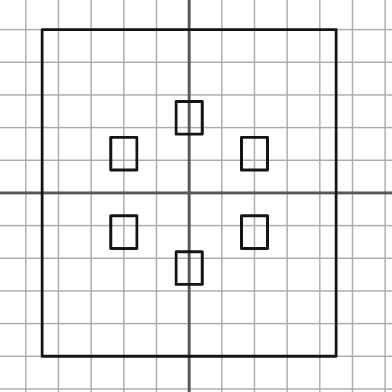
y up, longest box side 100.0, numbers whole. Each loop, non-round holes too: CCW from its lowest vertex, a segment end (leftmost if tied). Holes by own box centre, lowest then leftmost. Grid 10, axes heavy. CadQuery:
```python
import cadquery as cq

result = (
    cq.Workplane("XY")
    .moveTo(-45.0, -50.0)
    .lineTo(45.0, -50.0)
    .lineTo(45.0, 50.0)
    .lineTo(-45.0, 50.0)
    .close()
    .moveTo(-4.0, -28.0)
    .lineTo(4.0, -28.0)
    .lineTo(4.0, -18.0)
    .lineTo(-4.0, -18.0)
    .close()
    .moveTo(-24.0, -17.0)
    .lineTo(-16.0, -17.0)
    .lineTo(-16.0, -7.0)
    .lineTo(-24.0, -7.0)
    .close()
    .moveTo(16.0, -17.0)
    .lineTo(24.0, -17.0)
    .lineTo(24.0, -7.0)
    .lineTo(16.0, -7.0)
    .close()
    .moveTo(-24.0, 7.0)
    .lineTo(-16.0, 7.0)
    .lineTo(-16.0, 17.0)
    .lineTo(-24.0, 17.0)
    .close()
    .moveTo(16.0, 7.0)
    .lineTo(24.0, 7.0)
    .lineTo(24.0, 17.0)
    .lineTo(16.0, 17.0)
    .close()
    .moveTo(-4.0, 18.0)
    .lineTo(4.0, 18.0)
    .lineTo(4.0, 28.0)
    .lineTo(-4.0, 28.0)
    .close()
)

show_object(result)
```